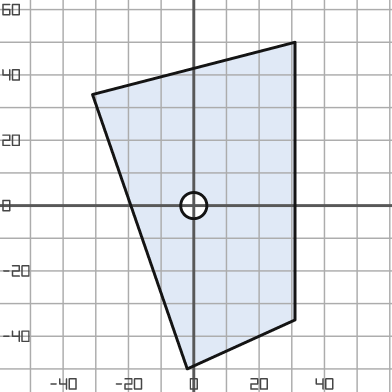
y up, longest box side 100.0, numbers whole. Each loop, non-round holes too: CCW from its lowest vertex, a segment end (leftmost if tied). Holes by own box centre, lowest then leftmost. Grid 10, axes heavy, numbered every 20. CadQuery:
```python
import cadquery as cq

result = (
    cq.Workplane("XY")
    .moveTo(-2.0, -50.0)
    .lineTo(31.0, -35.0)
    .lineTo(31.0, 50.0)
    .lineTo(-31.0, 34.0)
    .close()
    .moveTo(0.0, 0.0)
    .circle(4.0)
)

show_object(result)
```